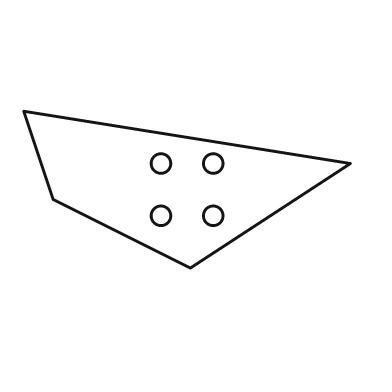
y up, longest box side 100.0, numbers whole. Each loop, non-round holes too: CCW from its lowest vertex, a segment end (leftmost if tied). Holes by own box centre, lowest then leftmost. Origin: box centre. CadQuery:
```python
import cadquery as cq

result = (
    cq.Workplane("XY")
    .moveTo(1.0, -24.0)
    .lineTo(50.0, 8.0)
    .lineTo(-50.0, 24.0)
    .lineTo(-41.0, -3.0)
    .close()
    .moveTo(-8.0, -8.0)
    .circle(3.0)
    .moveTo(8.0, -8.0)
    .circle(3.0)
    .moveTo(-8.0, 8.0)
    .circle(3.0)
    .moveTo(8.0, 8.0)
    .circle(3.0)
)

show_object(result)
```